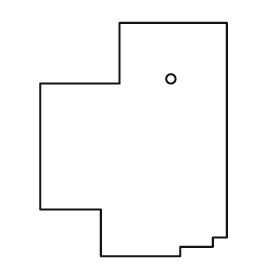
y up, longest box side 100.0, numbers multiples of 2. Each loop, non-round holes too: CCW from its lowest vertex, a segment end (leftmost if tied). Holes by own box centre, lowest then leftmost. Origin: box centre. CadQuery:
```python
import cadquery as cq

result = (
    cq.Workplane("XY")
    .moveTo(-14.0, -50.0)
    .lineTo(20.0, -50.0)
    .lineTo(20.0, -46.0)
    .lineTo(34.0, -46.0)
    .lineTo(34.0, -42.0)
    .lineTo(40.0, -42.0)
    .lineTo(40.0, 50.0)
    .lineTo(-6.0, 50.0)
    .lineTo(-6.0, 24.0)
    .lineTo(-40.0, 24.0)
    .lineTo(-40.0, -30.0)
    .lineTo(-14.0, -30.0)
    .close()
    .moveTo(16.0, 26.0)
    .circle(2.0)
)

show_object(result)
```